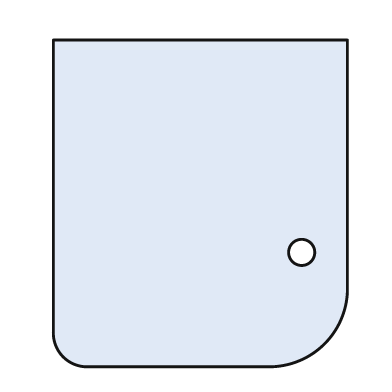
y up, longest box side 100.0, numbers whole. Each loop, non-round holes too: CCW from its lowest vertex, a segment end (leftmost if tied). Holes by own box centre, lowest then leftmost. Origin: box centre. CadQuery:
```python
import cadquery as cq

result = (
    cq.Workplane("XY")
    .moveTo(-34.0, -50.0)
    .lineTo(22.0, -50.0)
    .threePointArc((38.0, -43.0), (45.0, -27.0))
    .lineTo(45.0, 50.0)
    .lineTo(-45.0, 50.0)
    .lineTo(-45.0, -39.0)
    .threePointArc((-42.0, -47.0), (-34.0, -50.0))
    .close()
    .moveTo(31.0, -15.0)
    .circle(4.0)
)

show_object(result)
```